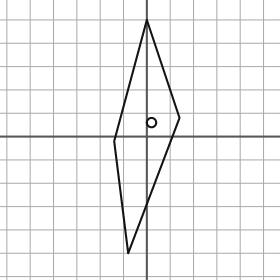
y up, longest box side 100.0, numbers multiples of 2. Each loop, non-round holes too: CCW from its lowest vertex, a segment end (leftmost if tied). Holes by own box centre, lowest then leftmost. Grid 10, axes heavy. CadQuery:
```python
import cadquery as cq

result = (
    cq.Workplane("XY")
    .moveTo(-8.0, -50.0)
    .lineTo(14.0, 8.0)
    .lineTo(0.0, 50.0)
    .lineTo(-14.0, -2.0)
    .close()
    .moveTo(2.0, 6.0)
    .circle(2.0)
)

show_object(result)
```